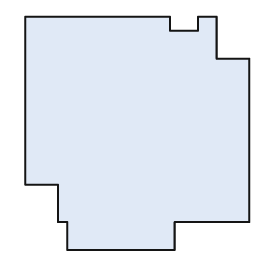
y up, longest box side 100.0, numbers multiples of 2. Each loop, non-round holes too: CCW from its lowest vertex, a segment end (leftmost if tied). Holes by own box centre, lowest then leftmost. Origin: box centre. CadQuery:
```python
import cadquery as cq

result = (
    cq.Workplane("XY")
    .moveTo(-30.0, -50.0)
    .lineTo(16.0, -50.0)
    .lineTo(16.0, -38.0)
    .lineTo(48.0, -38.0)
    .lineTo(48.0, 32.0)
    .lineTo(34.0, 32.0)
    .lineTo(34.0, 50.0)
    .lineTo(26.0, 50.0)
    .lineTo(26.0, 44.0)
    .lineTo(14.0, 44.0)
    .lineTo(14.0, 50.0)
    .lineTo(-48.0, 50.0)
    .lineTo(-48.0, -22.0)
    .lineTo(-34.0, -22.0)
    .lineTo(-34.0, -38.0)
    .lineTo(-30.0, -38.0)
    .close()
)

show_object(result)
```